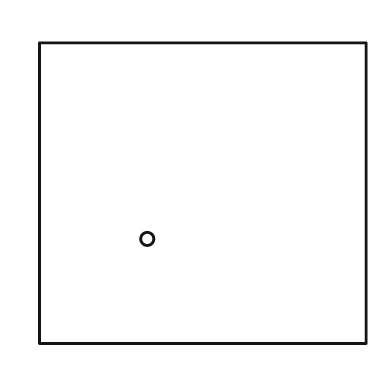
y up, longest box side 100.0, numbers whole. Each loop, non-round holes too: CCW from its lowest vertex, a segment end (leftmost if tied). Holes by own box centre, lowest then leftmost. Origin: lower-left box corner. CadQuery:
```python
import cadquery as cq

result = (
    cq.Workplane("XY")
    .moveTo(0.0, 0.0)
    .lineTo(100.0, 0.0)
    .lineTo(100.0, 92.0)
    .lineTo(0.0, 92.0)
    .close()
    .moveTo(33.0, 32.0)
    .circle(2.0)
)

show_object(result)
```